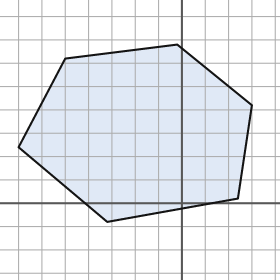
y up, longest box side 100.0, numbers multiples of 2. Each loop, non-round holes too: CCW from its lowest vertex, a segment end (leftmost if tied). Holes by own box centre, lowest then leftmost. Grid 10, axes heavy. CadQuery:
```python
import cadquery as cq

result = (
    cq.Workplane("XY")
    .moveTo(-32.0, -8.0)
    .lineTo(24.0, 2.0)
    .lineTo(30.0, 42.0)
    .lineTo(-2.0, 68.0)
    .lineTo(-50.0, 62.0)
    .lineTo(-70.0, 24.0)
    .close()
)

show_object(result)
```